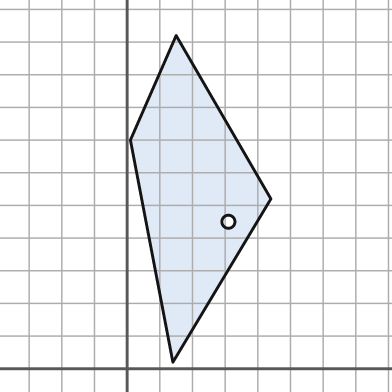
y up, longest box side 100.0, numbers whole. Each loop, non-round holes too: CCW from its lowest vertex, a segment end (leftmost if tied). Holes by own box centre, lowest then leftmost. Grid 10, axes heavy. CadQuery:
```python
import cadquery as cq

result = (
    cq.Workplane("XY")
    .moveTo(14.0, 2.0)
    .lineTo(44.0, 52.0)
    .lineTo(15.0, 102.0)
    .lineTo(1.0, 70.0)
    .close()
    .moveTo(31.0, 45.0)
    .circle(2.0)
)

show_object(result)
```